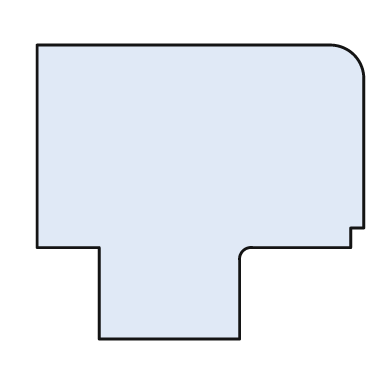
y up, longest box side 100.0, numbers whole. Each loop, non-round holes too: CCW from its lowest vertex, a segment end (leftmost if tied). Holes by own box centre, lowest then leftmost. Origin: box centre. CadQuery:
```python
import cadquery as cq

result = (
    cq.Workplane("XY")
    .moveTo(-31.0, -45.0)
    .lineTo(12.0, -45.0)
    .lineTo(12.0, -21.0)
    .threePointArc((13.0, -18.0), (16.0, -17.0))
    .lineTo(46.0, -17.0)
    .lineTo(46.0, -11.0)
    .lineTo(50.0, -11.0)
    .lineTo(50.0, 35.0)
    .threePointArc((47.0, 42.0), (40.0, 45.0))
    .lineTo(-50.0, 45.0)
    .lineTo(-50.0, -17.0)
    .lineTo(-31.0, -17.0)
    .close()
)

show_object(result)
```